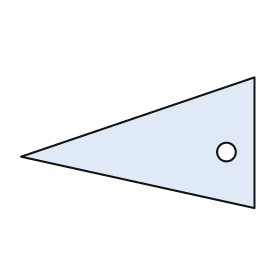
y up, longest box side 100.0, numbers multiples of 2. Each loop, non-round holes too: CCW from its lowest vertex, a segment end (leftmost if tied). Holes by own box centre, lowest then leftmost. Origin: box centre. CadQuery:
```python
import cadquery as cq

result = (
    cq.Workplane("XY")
    .moveTo(50.0, -28.0)
    .lineTo(50.0, 28.0)
    .lineTo(-50.0, -6.0)
    .close()
    .moveTo(38.0, -4.0)
    .circle(4.0)
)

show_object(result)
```